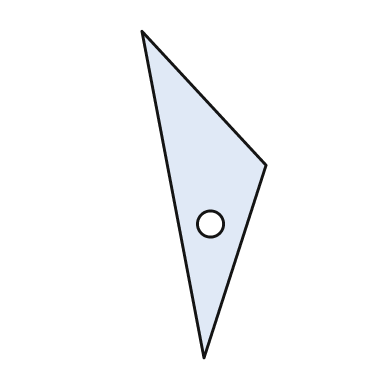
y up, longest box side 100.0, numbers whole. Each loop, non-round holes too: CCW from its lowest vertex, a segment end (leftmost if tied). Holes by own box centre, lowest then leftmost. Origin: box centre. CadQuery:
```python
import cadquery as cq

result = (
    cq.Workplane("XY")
    .moveTo(0.0, -50.0)
    .lineTo(19.0, 9.0)
    .lineTo(-19.0, 50.0)
    .close()
    .moveTo(2.0, -9.0)
    .circle(4.0)
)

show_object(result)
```